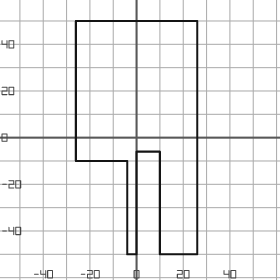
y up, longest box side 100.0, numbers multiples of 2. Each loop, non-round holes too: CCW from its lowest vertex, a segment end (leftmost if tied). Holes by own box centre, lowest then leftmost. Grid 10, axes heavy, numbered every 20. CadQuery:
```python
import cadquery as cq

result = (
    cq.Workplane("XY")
    .moveTo(-4.0, -50.0)
    .lineTo(0.0, -50.0)
    .lineTo(0.0, -6.0)
    .lineTo(10.0, -6.0)
    .lineTo(10.0, -50.0)
    .lineTo(26.0, -50.0)
    .lineTo(26.0, 50.0)
    .lineTo(-26.0, 50.0)
    .lineTo(-26.0, -10.0)
    .lineTo(-4.0, -10.0)
    .close()
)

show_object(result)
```